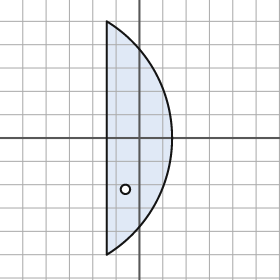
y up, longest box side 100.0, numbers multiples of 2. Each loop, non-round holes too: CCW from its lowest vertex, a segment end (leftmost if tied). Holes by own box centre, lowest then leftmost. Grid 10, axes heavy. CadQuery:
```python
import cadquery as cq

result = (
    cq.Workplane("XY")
    .moveTo(-14.0, -50.0)
    .threePointArc((14.0, 0.0), (-14.0, 50.0))
    .close()
    .moveTo(-6.0, -22.0)
    .circle(2.0)
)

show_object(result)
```